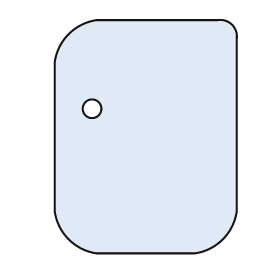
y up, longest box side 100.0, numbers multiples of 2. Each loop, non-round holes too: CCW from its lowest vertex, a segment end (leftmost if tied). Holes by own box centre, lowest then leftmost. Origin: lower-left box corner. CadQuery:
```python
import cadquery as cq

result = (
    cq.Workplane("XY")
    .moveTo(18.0, 0.0)
    .lineTo(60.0, 0.0)
    .threePointArc((72.0, 6.0), (78.0, 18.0))
    .lineTo(78.0, 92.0)
    .threePointArc((76.0, 98.0), (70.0, 100.0))
    .lineTo(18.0, 100.0)
    .threePointArc((6.0, 94.0), (0.0, 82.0))
    .lineTo(0.0, 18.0)
    .threePointArc((6.0, 6.0), (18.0, 0.0))
    .close()
    .moveTo(16.0, 62.0)
    .circle(4.0)
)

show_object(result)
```